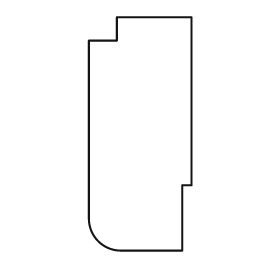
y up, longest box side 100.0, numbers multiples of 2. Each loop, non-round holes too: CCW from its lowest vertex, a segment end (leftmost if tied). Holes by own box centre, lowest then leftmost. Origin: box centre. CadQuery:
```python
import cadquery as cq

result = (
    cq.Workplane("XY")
    .moveTo(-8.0, -50.0)
    .lineTo(18.0, -50.0)
    .lineTo(18.0, -22.0)
    .lineTo(22.0, -22.0)
    .lineTo(22.0, 50.0)
    .lineTo(-10.0, 50.0)
    .lineTo(-10.0, 40.0)
    .lineTo(-22.0, 40.0)
    .lineTo(-22.0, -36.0)
    .threePointArc((-18.0, -46.0), (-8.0, -50.0))
    .close()
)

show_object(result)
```